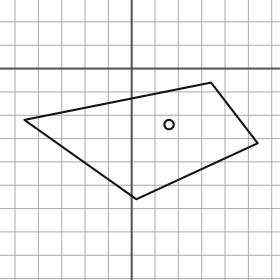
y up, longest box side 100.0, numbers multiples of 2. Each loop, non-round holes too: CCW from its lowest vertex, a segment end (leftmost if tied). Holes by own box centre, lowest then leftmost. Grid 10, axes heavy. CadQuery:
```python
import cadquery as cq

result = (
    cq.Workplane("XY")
    .moveTo(2.0, -56.0)
    .lineTo(54.0, -32.0)
    .lineTo(34.0, -6.0)
    .lineTo(-46.0, -22.0)
    .close()
    .moveTo(16.0, -24.0)
    .circle(2.0)
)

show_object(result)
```